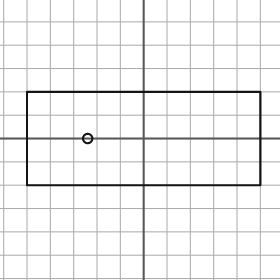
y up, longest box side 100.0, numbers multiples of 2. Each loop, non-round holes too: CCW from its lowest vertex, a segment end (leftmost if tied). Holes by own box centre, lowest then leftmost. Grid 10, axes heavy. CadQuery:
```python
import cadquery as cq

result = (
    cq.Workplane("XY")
    .moveTo(-50.0, -20.0)
    .lineTo(50.0, -20.0)
    .lineTo(50.0, 20.0)
    .lineTo(-50.0, 20.0)
    .close()
    .moveTo(-24.0, 0.0)
    .circle(2.0)
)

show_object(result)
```